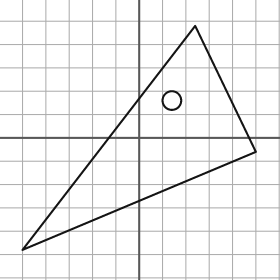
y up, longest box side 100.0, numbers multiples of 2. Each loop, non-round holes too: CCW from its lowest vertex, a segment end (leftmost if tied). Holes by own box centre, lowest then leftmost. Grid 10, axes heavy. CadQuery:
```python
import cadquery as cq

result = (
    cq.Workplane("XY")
    .moveTo(-50.0, -48.0)
    .lineTo(50.0, -6.0)
    .lineTo(24.0, 48.0)
    .close()
    .moveTo(14.0, 16.0)
    .circle(4.0)
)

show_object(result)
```